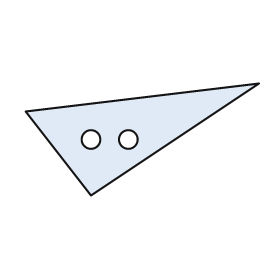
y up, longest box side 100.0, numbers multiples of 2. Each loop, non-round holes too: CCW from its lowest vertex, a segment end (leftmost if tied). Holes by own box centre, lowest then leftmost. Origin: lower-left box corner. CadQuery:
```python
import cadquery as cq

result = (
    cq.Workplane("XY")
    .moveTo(28.0, 0.0)
    .lineTo(100.0, 48.0)
    .lineTo(0.0, 36.0)
    .close()
    .moveTo(28.0, 24.0)
    .circle(4.0)
    .moveTo(44.0, 24.0)
    .circle(4.0)
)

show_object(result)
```